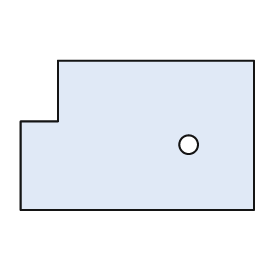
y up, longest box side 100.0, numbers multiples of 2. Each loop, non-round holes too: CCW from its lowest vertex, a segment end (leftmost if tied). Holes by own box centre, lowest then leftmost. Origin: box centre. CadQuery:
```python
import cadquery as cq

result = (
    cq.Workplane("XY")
    .moveTo(-50.0, -32.0)
    .lineTo(50.0, -32.0)
    .lineTo(50.0, 32.0)
    .lineTo(-34.0, 32.0)
    .lineTo(-34.0, 6.0)
    .lineTo(-50.0, 6.0)
    .close()
    .moveTo(22.0, -4.0)
    .circle(4.0)
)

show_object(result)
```